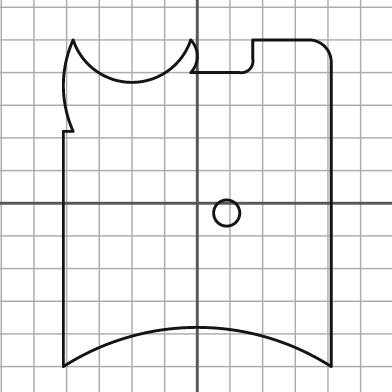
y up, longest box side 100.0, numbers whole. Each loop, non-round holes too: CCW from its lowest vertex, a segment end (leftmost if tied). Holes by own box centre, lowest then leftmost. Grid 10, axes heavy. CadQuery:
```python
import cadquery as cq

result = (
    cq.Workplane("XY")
    .moveTo(-41.0, -50.0)
    .threePointArc((0.0, -38.0), (41.0, -50.0))
    .lineTo(41.0, 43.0)
    .threePointArc((39.0, 48.0), (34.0, 50.0))
    .lineTo(17.0, 50.0)
    .lineTo(17.0, 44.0)
    .threePointArc((16.0, 41.0), (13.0, 40.0))
    .lineTo(-2.0, 40.0)
    .threePointArc((0.0, 45.0), (-2.0, 50.0))
    .threePointArc((-20.0, 37.0), (-38.0, 50.0))
    .threePointArc((-41.0, 36.0), (-38.0, 22.0))
    .lineTo(-41.0, 22.0)
    .close()
    .moveTo(9.0, -3.0)
    .circle(4.0)
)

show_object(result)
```